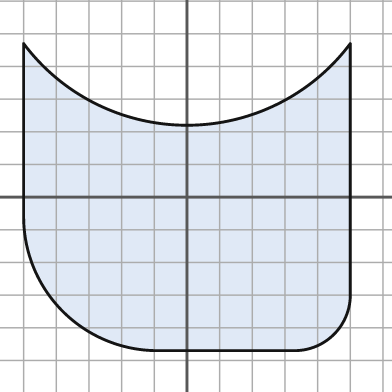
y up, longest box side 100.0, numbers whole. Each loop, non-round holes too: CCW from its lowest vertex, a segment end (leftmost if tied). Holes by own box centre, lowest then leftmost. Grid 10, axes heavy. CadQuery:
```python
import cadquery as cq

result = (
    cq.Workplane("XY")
    .moveTo(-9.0, -47.0)
    .lineTo(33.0, -47.0)
    .threePointArc((45.0, -42.0), (50.0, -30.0))
    .lineTo(50.0, 47.0)
    .threePointArc((0.0, 22.0), (-50.0, 47.0))
    .lineTo(-50.0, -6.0)
    .threePointArc((-38.0, -35.0), (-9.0, -47.0))
    .close()
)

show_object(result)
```